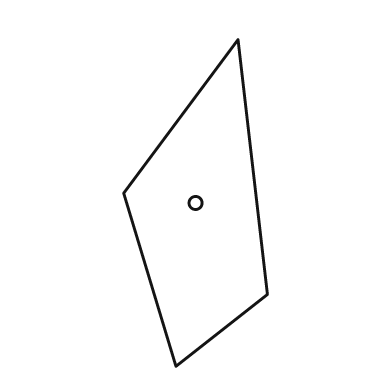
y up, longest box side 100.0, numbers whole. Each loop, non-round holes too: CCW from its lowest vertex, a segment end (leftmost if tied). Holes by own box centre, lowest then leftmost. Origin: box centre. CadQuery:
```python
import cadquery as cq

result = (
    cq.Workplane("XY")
    .moveTo(-6.0, -50.0)
    .lineTo(22.0, -28.0)
    .lineTo(13.0, 50.0)
    .lineTo(-22.0, 3.0)
    .close()
    .moveTo(0.0, 0.0)
    .circle(2.0)
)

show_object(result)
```